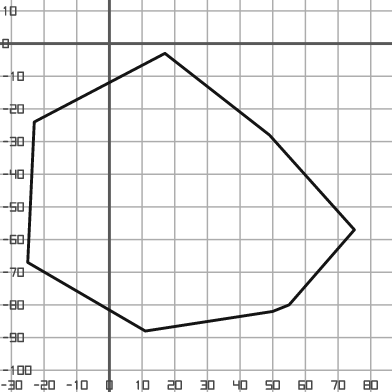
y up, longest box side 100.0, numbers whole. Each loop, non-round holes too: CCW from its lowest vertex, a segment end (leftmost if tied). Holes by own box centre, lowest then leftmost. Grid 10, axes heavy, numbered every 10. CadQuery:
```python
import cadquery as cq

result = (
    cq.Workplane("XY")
    .moveTo(11.0, -88.0)
    .lineTo(50.0, -82.0)
    .lineTo(55.0, -80.0)
    .lineTo(75.0, -57.0)
    .lineTo(49.0, -28.0)
    .lineTo(17.0, -3.0)
    .lineTo(-23.0, -24.0)
    .lineTo(-25.0, -67.0)
    .close()
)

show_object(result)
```